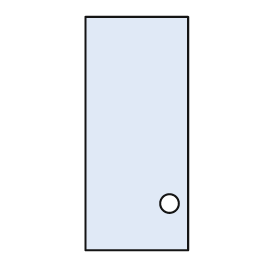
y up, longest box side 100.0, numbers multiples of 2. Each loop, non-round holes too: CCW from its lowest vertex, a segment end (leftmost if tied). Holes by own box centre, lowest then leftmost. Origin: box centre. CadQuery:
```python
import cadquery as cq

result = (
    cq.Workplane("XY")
    .moveTo(-22.0, -50.0)
    .lineTo(22.0, -50.0)
    .lineTo(22.0, 50.0)
    .lineTo(-22.0, 50.0)
    .close()
    .moveTo(14.0, -30.0)
    .circle(4.0)
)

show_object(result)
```